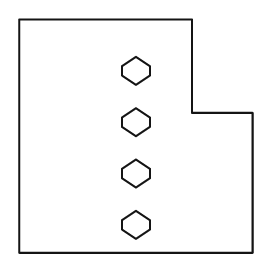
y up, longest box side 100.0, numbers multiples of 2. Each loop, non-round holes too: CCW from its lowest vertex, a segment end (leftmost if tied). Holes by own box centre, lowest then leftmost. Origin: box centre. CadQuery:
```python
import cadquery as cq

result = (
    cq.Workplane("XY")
    .moveTo(-50.0, -50.0)
    .lineTo(50.0, -50.0)
    .lineTo(50.0, 10.0)
    .lineTo(24.0, 10.0)
    .lineTo(24.0, 50.0)
    .lineTo(-50.0, 50.0)
    .close()
    .moveTo(0.0, -44.0)
    .lineTo(6.0, -40.0)
    .lineTo(6.0, -36.0)
    .lineTo(0.0, -32.0)
    .lineTo(-6.0, -36.0)
    .lineTo(-6.0, -40.0)
    .close()
    .moveTo(0.0, -22.0)
    .lineTo(6.0, -18.0)
    .lineTo(6.0, -14.0)
    .lineTo(0.0, -10.0)
    .lineTo(-6.0, -14.0)
    .lineTo(-6.0, -18.0)
    .close()
    .moveTo(0.0, 0.0)
    .lineTo(6.0, 4.0)
    .lineTo(6.0, 8.0)
    .lineTo(0.0, 12.0)
    .lineTo(-6.0, 8.0)
    .lineTo(-6.0, 4.0)
    .close()
    .moveTo(0.0, 22.0)
    .lineTo(6.0, 26.0)
    .lineTo(6.0, 30.0)
    .lineTo(0.0, 34.0)
    .lineTo(-6.0, 30.0)
    .lineTo(-6.0, 26.0)
    .close()
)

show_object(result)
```